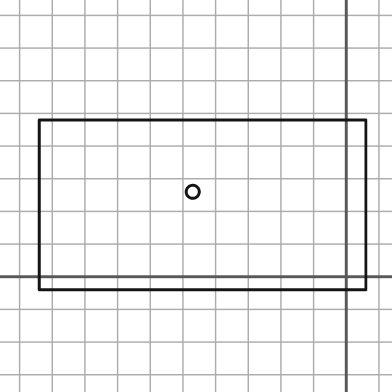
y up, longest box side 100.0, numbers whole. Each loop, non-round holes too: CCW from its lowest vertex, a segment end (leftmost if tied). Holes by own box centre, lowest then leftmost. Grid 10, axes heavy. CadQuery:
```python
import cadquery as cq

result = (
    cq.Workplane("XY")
    .moveTo(-94.0, -4.0)
    .lineTo(6.0, -4.0)
    .lineTo(6.0, 48.0)
    .lineTo(-94.0, 48.0)
    .close()
    .moveTo(-47.0, 26.0)
    .circle(2.0)
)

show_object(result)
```